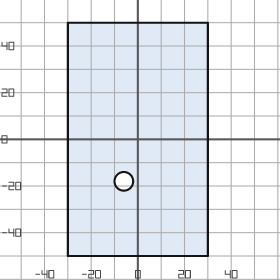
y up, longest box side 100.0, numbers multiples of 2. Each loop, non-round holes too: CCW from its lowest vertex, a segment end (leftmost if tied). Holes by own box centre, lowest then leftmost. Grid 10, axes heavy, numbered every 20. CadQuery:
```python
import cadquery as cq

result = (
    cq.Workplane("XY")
    .moveTo(-30.0, -50.0)
    .lineTo(30.0, -50.0)
    .lineTo(30.0, 50.0)
    .lineTo(-30.0, 50.0)
    .close()
    .moveTo(-6.0, -18.0)
    .circle(4.0)
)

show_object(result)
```